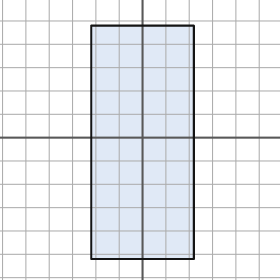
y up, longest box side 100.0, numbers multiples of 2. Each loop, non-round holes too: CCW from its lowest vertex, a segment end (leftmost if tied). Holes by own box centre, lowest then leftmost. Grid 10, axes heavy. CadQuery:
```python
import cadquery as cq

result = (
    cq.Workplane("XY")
    .moveTo(-22.0, -52.0)
    .lineTo(22.0, -52.0)
    .lineTo(22.0, 48.0)
    .lineTo(-22.0, 48.0)
    .close()
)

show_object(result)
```